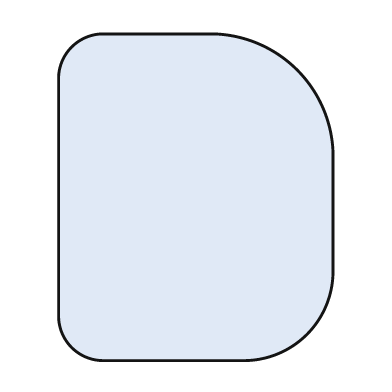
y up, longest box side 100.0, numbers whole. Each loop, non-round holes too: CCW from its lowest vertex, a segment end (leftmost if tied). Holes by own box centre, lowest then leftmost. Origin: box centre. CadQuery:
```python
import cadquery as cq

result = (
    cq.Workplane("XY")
    .moveTo(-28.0, -50.0)
    .lineTo(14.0, -50.0)
    .threePointArc((34.0, -42.0), (42.0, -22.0))
    .lineTo(42.0, 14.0)
    .threePointArc((31.0, 39.0), (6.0, 50.0))
    .lineTo(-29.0, 50.0)
    .threePointArc((-38.0, 46.0), (-42.0, 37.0))
    .lineTo(-42.0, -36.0)
    .threePointArc((-38.0, -46.0), (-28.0, -50.0))
    .close()
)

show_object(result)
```